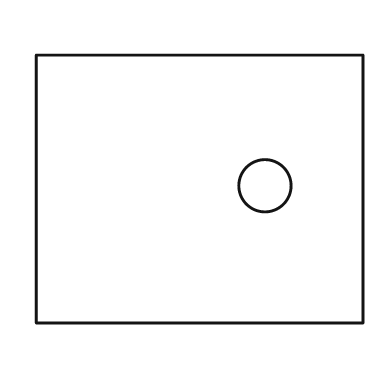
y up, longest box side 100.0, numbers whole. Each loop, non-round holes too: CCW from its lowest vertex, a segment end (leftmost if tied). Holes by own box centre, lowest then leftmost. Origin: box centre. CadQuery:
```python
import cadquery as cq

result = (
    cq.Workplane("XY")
    .moveTo(-50.0, -41.0)
    .lineTo(50.0, -41.0)
    .lineTo(50.0, 41.0)
    .lineTo(-50.0, 41.0)
    .close()
    .moveTo(20.0, 1.0)
    .circle(8.0)
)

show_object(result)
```